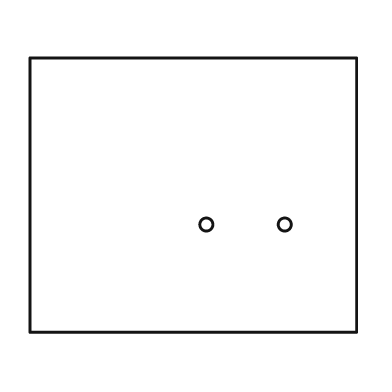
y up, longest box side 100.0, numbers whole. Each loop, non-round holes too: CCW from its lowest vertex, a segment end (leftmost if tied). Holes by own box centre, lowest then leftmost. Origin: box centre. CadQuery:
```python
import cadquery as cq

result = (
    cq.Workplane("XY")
    .moveTo(-50.0, -42.0)
    .lineTo(50.0, -42.0)
    .lineTo(50.0, 42.0)
    .lineTo(-50.0, 42.0)
    .close()
    .moveTo(4.0, -9.0)
    .circle(2.0)
    .moveTo(28.0, -9.0)
    .circle(2.0)
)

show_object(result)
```